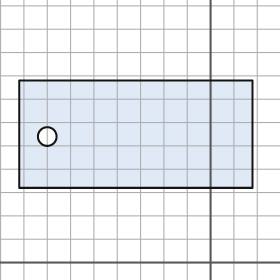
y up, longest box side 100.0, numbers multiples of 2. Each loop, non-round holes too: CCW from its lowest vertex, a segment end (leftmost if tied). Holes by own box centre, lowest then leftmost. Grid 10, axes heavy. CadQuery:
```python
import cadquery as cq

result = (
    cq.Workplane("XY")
    .moveTo(-82.0, 32.0)
    .lineTo(18.0, 32.0)
    .lineTo(18.0, 78.0)
    .lineTo(-82.0, 78.0)
    .close()
    .moveTo(-70.0, 54.0)
    .circle(4.0)
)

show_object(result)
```